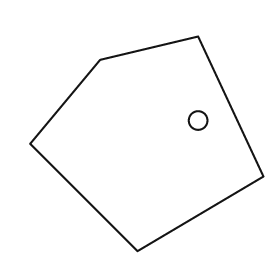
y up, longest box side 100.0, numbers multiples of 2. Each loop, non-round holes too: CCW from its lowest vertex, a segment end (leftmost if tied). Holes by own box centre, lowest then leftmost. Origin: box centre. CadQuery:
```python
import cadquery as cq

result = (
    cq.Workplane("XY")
    .moveTo(-4.0, -46.0)
    .lineTo(50.0, -14.0)
    .lineTo(22.0, 46.0)
    .lineTo(-20.0, 36.0)
    .lineTo(-50.0, 0.0)
    .close()
    .moveTo(22.0, 10.0)
    .circle(4.0)
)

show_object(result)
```